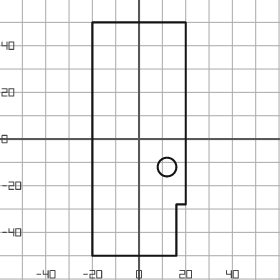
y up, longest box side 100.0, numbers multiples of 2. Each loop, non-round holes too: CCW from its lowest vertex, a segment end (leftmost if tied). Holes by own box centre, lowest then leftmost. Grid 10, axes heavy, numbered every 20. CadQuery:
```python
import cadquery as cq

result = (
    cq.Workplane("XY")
    .moveTo(-20.0, -50.0)
    .lineTo(16.0, -50.0)
    .lineTo(16.0, -28.0)
    .lineTo(20.0, -28.0)
    .lineTo(20.0, 50.0)
    .lineTo(-20.0, 50.0)
    .close()
    .moveTo(12.0, -12.0)
    .circle(4.0)
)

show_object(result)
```